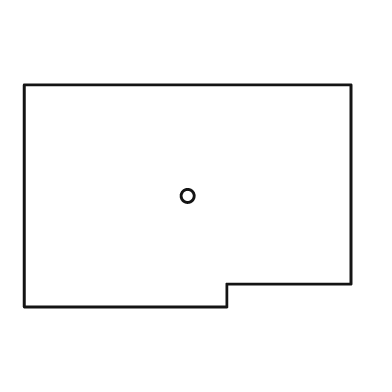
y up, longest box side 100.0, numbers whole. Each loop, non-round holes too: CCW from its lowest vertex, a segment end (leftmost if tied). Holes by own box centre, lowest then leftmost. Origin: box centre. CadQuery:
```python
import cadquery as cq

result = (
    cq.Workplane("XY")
    .moveTo(-50.0, -34.0)
    .lineTo(12.0, -34.0)
    .lineTo(12.0, -27.0)
    .lineTo(50.0, -27.0)
    .lineTo(50.0, 34.0)
    .lineTo(-50.0, 34.0)
    .close()
    .moveTo(0.0, 0.0)
    .circle(2.0)
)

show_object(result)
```